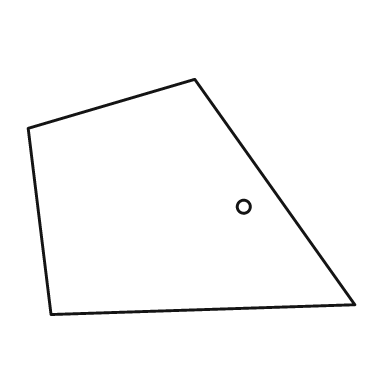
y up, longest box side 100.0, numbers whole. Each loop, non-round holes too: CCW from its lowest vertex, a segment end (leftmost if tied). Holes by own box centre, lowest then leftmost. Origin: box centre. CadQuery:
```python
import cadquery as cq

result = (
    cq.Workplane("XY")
    .moveTo(-43.0, -36.0)
    .lineTo(50.0, -33.0)
    .lineTo(1.0, 36.0)
    .lineTo(-50.0, 21.0)
    .close()
    .moveTo(16.0, -3.0)
    .circle(2.0)
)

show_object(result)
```